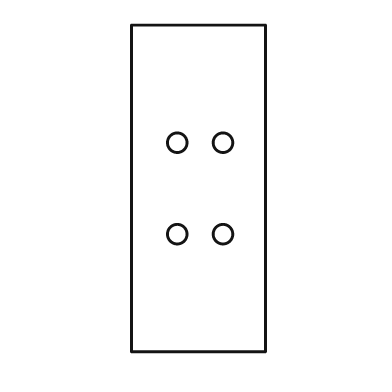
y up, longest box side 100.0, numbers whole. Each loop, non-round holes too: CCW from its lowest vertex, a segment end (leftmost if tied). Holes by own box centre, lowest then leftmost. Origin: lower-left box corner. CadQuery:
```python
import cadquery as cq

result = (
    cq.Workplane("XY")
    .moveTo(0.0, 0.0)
    .lineTo(41.0, 0.0)
    .lineTo(41.0, 100.0)
    .lineTo(0.0, 100.0)
    .close()
    .moveTo(14.0, 36.0)
    .circle(3.0)
    .moveTo(28.0, 36.0)
    .circle(3.0)
    .moveTo(14.0, 64.0)
    .circle(3.0)
    .moveTo(28.0, 64.0)
    .circle(3.0)
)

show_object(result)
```